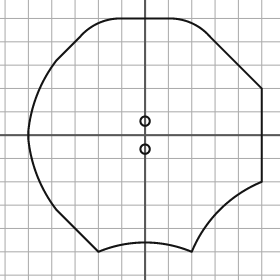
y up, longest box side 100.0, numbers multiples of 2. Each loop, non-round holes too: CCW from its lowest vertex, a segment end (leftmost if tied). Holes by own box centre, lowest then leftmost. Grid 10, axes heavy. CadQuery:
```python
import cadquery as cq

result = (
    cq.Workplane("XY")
    .moveTo(-20.0, -50.0)
    .threePointArc((0.0, -46.0), (20.0, -50.0))
    .threePointArc((32.0, -32.0), (50.0, -20.0))
    .lineTo(50.0, 20.0)
    .lineTo(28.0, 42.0)
    .threePointArc((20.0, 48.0), (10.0, 50.0))
    .lineTo(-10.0, 50.0)
    .threePointArc((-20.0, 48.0), (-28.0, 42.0))
    .lineTo(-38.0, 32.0)
    .threePointArc((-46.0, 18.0), (-50.0, 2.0))
    .lineTo(-50.0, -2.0)
    .threePointArc((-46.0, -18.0), (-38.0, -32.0))
    .close()
    .moveTo(0.0, -6.0)
    .circle(2.0)
    .moveTo(0.0, 6.0)
    .circle(2.0)
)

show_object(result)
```